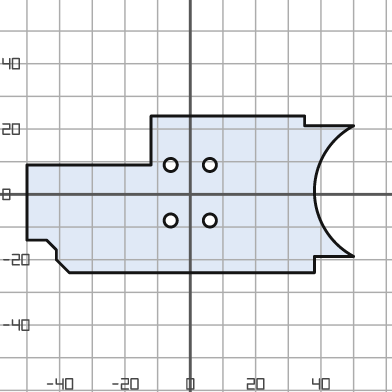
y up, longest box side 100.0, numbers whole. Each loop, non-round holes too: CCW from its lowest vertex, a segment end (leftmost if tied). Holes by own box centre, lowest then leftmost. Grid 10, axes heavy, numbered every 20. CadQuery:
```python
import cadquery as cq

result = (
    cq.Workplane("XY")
    .moveTo(-37.0, -24.0)
    .lineTo(38.0, -24.0)
    .lineTo(38.0, -19.0)
    .lineTo(50.0, -19.0)
    .threePointArc((38.0, 1.0), (50.0, 21.0))
    .lineTo(35.0, 21.0)
    .lineTo(35.0, 24.0)
    .lineTo(-12.0, 24.0)
    .lineTo(-12.0, 9.0)
    .lineTo(-50.0, 9.0)
    .lineTo(-50.0, -14.0)
    .lineTo(-44.0, -14.0)
    .lineTo(-41.0, -17.0)
    .lineTo(-41.0, -20.0)
    .close()
    .moveTo(-6.0, -8.0)
    .circle(2.0)
    .moveTo(6.0, -8.0)
    .circle(2.0)
    .moveTo(-6.0, 9.0)
    .circle(2.0)
    .moveTo(6.0, 9.0)
    .circle(2.0)
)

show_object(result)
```